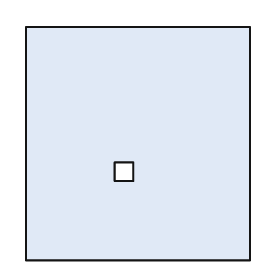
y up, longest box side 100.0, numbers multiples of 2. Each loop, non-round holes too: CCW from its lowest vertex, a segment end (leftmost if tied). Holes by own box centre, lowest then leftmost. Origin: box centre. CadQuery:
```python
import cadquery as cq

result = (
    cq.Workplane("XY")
    .moveTo(-48.0, -50.0)
    .lineTo(48.0, -50.0)
    .lineTo(48.0, 50.0)
    .lineTo(-48.0, 50.0)
    .close()
    .moveTo(-10.0, -16.0)
    .lineTo(-2.0, -16.0)
    .lineTo(-2.0, -8.0)
    .lineTo(-10.0, -8.0)
    .close()
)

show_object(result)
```